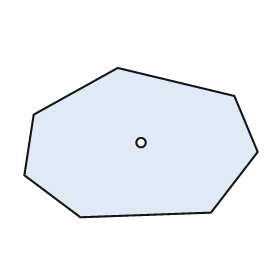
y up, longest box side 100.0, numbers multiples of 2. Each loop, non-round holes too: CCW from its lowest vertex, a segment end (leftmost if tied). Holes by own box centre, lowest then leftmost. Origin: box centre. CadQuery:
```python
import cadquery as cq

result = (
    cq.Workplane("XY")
    .moveTo(-26.0, -32.0)
    .lineTo(30.0, -30.0)
    .lineTo(50.0, -4.0)
    .lineTo(40.0, 20.0)
    .lineTo(-10.0, 32.0)
    .lineTo(-46.0, 12.0)
    .lineTo(-50.0, -14.0)
    .close()
    .moveTo(0.0, 0.0)
    .circle(2.0)
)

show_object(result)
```